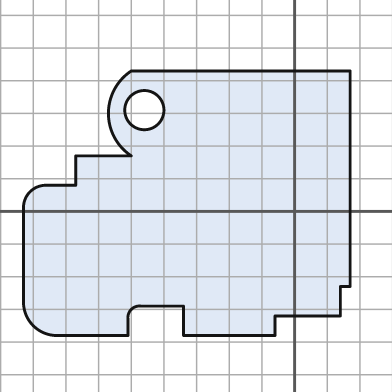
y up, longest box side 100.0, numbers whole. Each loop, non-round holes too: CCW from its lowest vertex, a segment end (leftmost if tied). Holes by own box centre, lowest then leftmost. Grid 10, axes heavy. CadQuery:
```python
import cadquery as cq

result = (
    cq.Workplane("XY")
    .moveTo(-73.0, -38.0)
    .lineTo(-51.0, -38.0)
    .lineTo(-51.0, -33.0)
    .threePointArc((-50.0, -30.0), (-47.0, -29.0))
    .lineTo(-34.0, -29.0)
    .lineTo(-34.0, -38.0)
    .lineTo(-6.0, -38.0)
    .lineTo(-6.0, -32.0)
    .lineTo(14.0, -32.0)
    .lineTo(14.0, -23.0)
    .lineTo(17.0, -23.0)
    .lineTo(17.0, 43.0)
    .lineTo(-50.0, 43.0)
    .threePointArc((-57.0, 30.0), (-50.0, 17.0))
    .lineTo(-67.0, 17.0)
    .lineTo(-67.0, 8.0)
    .lineTo(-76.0, 8.0)
    .threePointArc((-81.0, 6.0), (-83.0, 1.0))
    .lineTo(-83.0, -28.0)
    .threePointArc((-80.0, -35.0), (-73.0, -38.0))
    .close()
    .moveTo(-46.0, 31.0)
    .circle(6.0)
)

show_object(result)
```